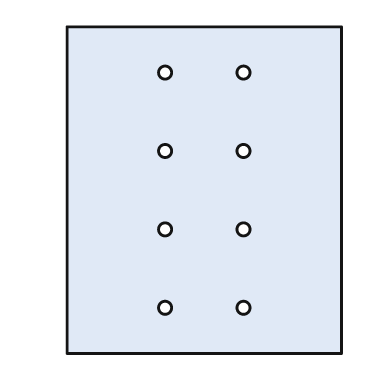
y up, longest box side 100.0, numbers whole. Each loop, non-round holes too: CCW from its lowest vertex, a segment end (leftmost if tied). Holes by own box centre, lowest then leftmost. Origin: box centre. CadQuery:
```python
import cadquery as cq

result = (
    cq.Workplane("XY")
    .moveTo(-42.0, -50.0)
    .lineTo(42.0, -50.0)
    .lineTo(42.0, 50.0)
    .lineTo(-42.0, 50.0)
    .close()
    .moveTo(-12.0, -36.0)
    .circle(2.0)
    .moveTo(12.0, -36.0)
    .circle(2.0)
    .moveTo(-12.0, -12.0)
    .circle(2.0)
    .moveTo(12.0, -12.0)
    .circle(2.0)
    .moveTo(-12.0, 12.0)
    .circle(2.0)
    .moveTo(12.0, 12.0)
    .circle(2.0)
    .moveTo(-12.0, 36.0)
    .circle(2.0)
    .moveTo(12.0, 36.0)
    .circle(2.0)
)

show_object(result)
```